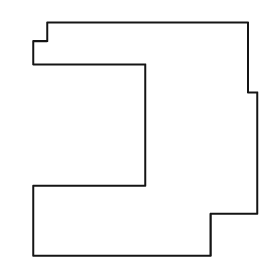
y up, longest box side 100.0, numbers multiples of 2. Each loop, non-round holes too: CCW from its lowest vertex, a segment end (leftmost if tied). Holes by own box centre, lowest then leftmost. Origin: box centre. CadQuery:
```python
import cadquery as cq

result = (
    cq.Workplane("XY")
    .moveTo(-48.0, -50.0)
    .lineTo(28.0, -50.0)
    .lineTo(28.0, -32.0)
    .lineTo(48.0, -32.0)
    .lineTo(48.0, 20.0)
    .lineTo(44.0, 20.0)
    .lineTo(44.0, 50.0)
    .lineTo(-42.0, 50.0)
    .lineTo(-42.0, 42.0)
    .lineTo(-48.0, 42.0)
    .lineTo(-48.0, 32.0)
    .lineTo(0.0, 32.0)
    .lineTo(0.0, -20.0)
    .lineTo(-48.0, -20.0)
    .close()
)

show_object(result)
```